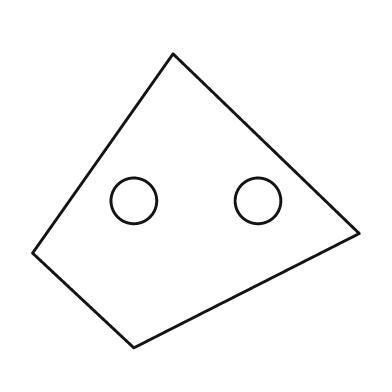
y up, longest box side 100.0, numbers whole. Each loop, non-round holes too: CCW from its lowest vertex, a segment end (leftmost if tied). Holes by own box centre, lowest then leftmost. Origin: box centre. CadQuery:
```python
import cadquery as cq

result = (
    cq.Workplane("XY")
    .moveTo(-19.0, -45.0)
    .lineTo(50.0, -10.0)
    .lineTo(-7.0, 45.0)
    .lineTo(-50.0, -16.0)
    .close()
    .moveTo(-19.0, 0.0)
    .circle(7.0)
    .moveTo(19.0, 0.0)
    .circle(7.0)
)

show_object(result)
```